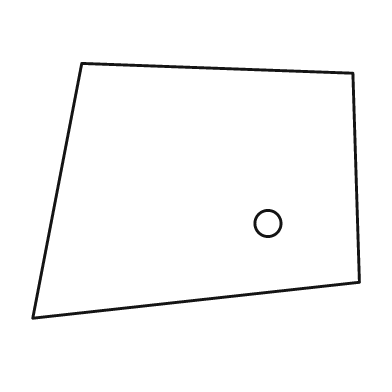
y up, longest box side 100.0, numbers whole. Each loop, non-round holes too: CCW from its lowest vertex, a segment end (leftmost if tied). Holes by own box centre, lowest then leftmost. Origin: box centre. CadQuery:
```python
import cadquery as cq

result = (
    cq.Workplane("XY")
    .moveTo(-50.0, -39.0)
    .lineTo(50.0, -28.0)
    .lineTo(48.0, 36.0)
    .lineTo(-35.0, 39.0)
    .close()
    .moveTo(22.0, -10.0)
    .circle(4.0)
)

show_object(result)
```